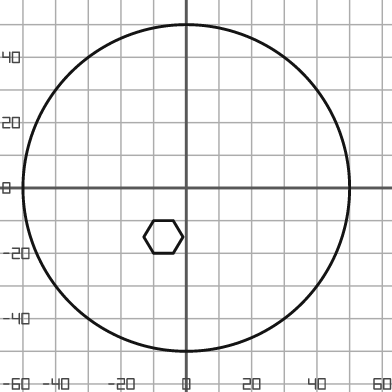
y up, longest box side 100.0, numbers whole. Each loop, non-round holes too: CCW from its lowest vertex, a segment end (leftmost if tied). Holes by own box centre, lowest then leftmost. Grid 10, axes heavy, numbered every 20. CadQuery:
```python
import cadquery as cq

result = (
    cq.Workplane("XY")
    .moveTo(0.0, 0.0)
    .circle(50.0)
    .moveTo(-10.0, -20.0)
    .lineTo(-4.0, -20.0)
    .lineTo(-1.0, -15.0)
    .lineTo(-4.0, -10.0)
    .lineTo(-10.0, -10.0)
    .lineTo(-13.0, -15.0)
    .close()
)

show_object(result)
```